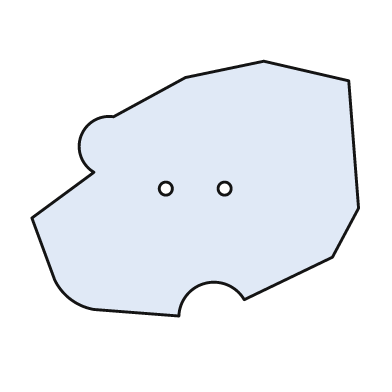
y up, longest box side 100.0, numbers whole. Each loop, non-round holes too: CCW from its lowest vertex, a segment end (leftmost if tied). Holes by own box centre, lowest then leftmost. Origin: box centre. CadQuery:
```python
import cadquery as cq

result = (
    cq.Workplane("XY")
    .moveTo(-5.0, -39.0)
    .threePointArc((3.0, -29.0), (15.0, -34.0))
    .lineTo(42.0, -21.0)
    .lineTo(50.0, -6.0)
    .lineTo(47.0, 33.0)
    .lineTo(21.0, 39.0)
    .lineTo(-3.0, 34.0)
    .lineTo(-25.0, 22.0)
    .threePointArc((-35.0, 16.0), (-31.0, 5.0))
    .lineTo(-50.0, -9.0)
    .lineTo(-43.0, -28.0)
    .threePointArc((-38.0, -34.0), (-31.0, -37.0))
    .close()
    .moveTo(-9.0, 0.0)
    .circle(2.0)
    .moveTo(9.0, 0.0)
    .circle(2.0)
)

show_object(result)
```